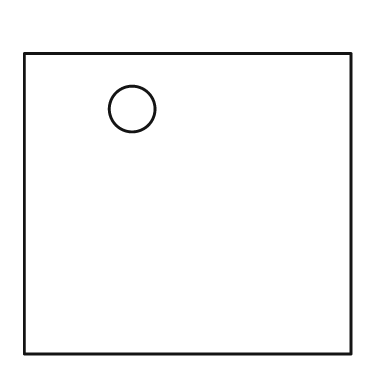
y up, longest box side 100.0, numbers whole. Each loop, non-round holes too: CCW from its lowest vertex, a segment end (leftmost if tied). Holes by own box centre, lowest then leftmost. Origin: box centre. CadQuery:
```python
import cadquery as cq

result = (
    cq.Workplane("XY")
    .moveTo(-50.0, -46.0)
    .lineTo(50.0, -46.0)
    .lineTo(50.0, 46.0)
    .lineTo(-50.0, 46.0)
    .close()
    .moveTo(-17.0, 29.0)
    .circle(7.0)
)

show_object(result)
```